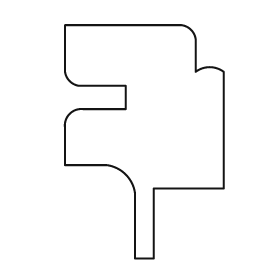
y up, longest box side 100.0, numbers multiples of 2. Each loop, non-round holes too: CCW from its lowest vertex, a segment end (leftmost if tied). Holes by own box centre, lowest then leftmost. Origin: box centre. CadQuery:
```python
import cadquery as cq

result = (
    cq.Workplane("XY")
    .moveTo(-4.0, -50.0)
    .lineTo(4.0, -50.0)
    .lineTo(4.0, -20.0)
    .lineTo(34.0, -20.0)
    .lineTo(34.0, 30.0)
    .threePointArc((28.0, 32.0), (22.0, 30.0))
    .lineTo(22.0, 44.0)
    .threePointArc((20.0, 48.0), (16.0, 50.0))
    .lineTo(-34.0, 50.0)
    .lineTo(-34.0, 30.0)
    .threePointArc((-32.0, 26.0), (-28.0, 24.0))
    .lineTo(-8.0, 24.0)
    .lineTo(-8.0, 14.0)
    .lineTo(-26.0, 14.0)
    .threePointArc((-32.0, 12.0), (-34.0, 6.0))
    .lineTo(-34.0, -10.0)
    .lineTo(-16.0, -10.0)
    .threePointArc((-8.0, -14.0), (-4.0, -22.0))
    .close()
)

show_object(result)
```